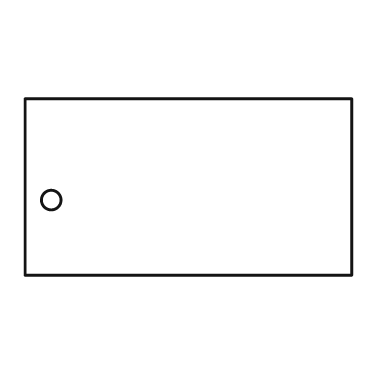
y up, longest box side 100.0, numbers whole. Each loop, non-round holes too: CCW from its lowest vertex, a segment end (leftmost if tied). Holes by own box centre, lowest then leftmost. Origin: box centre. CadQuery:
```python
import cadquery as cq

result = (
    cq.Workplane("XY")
    .moveTo(-50.0, -27.0)
    .lineTo(50.0, -27.0)
    .lineTo(50.0, 27.0)
    .lineTo(-50.0, 27.0)
    .close()
    .moveTo(-42.0, -4.0)
    .circle(3.0)
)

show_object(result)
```